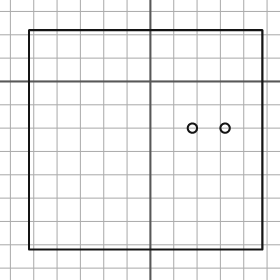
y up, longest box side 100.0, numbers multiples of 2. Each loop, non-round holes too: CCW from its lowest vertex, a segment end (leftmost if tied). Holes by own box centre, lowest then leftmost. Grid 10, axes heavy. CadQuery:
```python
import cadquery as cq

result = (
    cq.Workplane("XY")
    .moveTo(-52.0, -72.0)
    .lineTo(48.0, -72.0)
    .lineTo(48.0, 22.0)
    .lineTo(-52.0, 22.0)
    .close()
    .moveTo(18.0, -20.0)
    .circle(2.0)
    .moveTo(32.0, -20.0)
    .circle(2.0)
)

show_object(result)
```